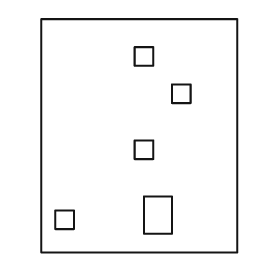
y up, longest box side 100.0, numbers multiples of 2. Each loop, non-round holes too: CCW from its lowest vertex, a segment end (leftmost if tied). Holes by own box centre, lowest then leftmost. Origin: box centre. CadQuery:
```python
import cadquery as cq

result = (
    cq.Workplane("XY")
    .moveTo(-42.0, -50.0)
    .lineTo(42.0, -50.0)
    .lineTo(42.0, 50.0)
    .lineTo(-42.0, 50.0)
    .close()
    .moveTo(-36.0, -40.0)
    .lineTo(-28.0, -40.0)
    .lineTo(-28.0, -32.0)
    .lineTo(-36.0, -32.0)
    .close()
    .moveTo(2.0, -42.0)
    .lineTo(14.0, -42.0)
    .lineTo(14.0, -26.0)
    .lineTo(2.0, -26.0)
    .close()
    .moveTo(-2.0, -10.0)
    .lineTo(6.0, -10.0)
    .lineTo(6.0, -2.0)
    .lineTo(-2.0, -2.0)
    .close()
    .moveTo(14.0, 14.0)
    .lineTo(22.0, 14.0)
    .lineTo(22.0, 22.0)
    .lineTo(14.0, 22.0)
    .close()
    .moveTo(-2.0, 30.0)
    .lineTo(6.0, 30.0)
    .lineTo(6.0, 38.0)
    .lineTo(-2.0, 38.0)
    .close()
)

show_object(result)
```